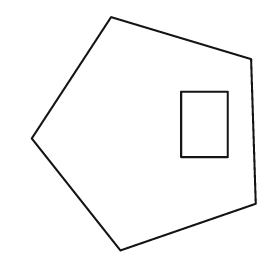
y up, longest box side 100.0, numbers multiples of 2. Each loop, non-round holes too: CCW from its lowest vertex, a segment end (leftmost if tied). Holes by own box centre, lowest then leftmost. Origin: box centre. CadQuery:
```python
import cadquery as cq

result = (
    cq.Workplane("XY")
    .moveTo(-10.0, -50.0)
    .lineTo(48.0, -30.0)
    .lineTo(46.0, 32.0)
    .lineTo(-14.0, 50.0)
    .lineTo(-48.0, -2.0)
    .close()
    .moveTo(16.0, -10.0)
    .lineTo(36.0, -10.0)
    .lineTo(36.0, 18.0)
    .lineTo(16.0, 18.0)
    .close()
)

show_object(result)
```